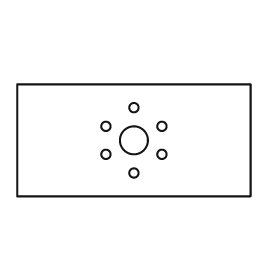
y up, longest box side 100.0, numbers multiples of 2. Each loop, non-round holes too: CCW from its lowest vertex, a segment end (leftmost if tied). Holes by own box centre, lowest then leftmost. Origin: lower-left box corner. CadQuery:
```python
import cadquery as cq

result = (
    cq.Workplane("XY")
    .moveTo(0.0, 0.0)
    .lineTo(100.0, 0.0)
    .lineTo(100.0, 48.0)
    .lineTo(0.0, 48.0)
    .close()
    .moveTo(50.0, 10.0)
    .circle(2.0)
    .moveTo(38.0, 18.0)
    .circle(2.0)
    .moveTo(62.0, 18.0)
    .circle(2.0)
    .moveTo(50.0, 24.0)
    .circle(6.0)
    .moveTo(38.0, 30.0)
    .circle(2.0)
    .moveTo(62.0, 30.0)
    .circle(2.0)
    .moveTo(50.0, 38.0)
    .circle(2.0)
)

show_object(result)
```